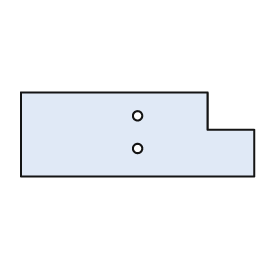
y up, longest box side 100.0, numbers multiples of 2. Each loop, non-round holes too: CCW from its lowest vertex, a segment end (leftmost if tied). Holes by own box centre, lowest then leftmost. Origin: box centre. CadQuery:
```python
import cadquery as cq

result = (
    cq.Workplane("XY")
    .moveTo(-50.0, -18.0)
    .lineTo(50.0, -18.0)
    .lineTo(50.0, 2.0)
    .lineTo(30.0, 2.0)
    .lineTo(30.0, 18.0)
    .lineTo(-50.0, 18.0)
    .close()
    .moveTo(0.0, -6.0)
    .circle(2.0)
    .moveTo(0.0, 8.0)
    .circle(2.0)
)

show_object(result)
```